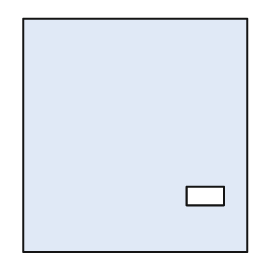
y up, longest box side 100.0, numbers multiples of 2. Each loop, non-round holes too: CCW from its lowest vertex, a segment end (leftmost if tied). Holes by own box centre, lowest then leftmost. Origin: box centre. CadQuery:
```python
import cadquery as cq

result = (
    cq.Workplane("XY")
    .moveTo(-48.0, -50.0)
    .lineTo(48.0, -50.0)
    .lineTo(48.0, 50.0)
    .lineTo(-48.0, 50.0)
    .close()
    .moveTo(22.0, -30.0)
    .lineTo(38.0, -30.0)
    .lineTo(38.0, -22.0)
    .lineTo(22.0, -22.0)
    .close()
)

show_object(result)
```